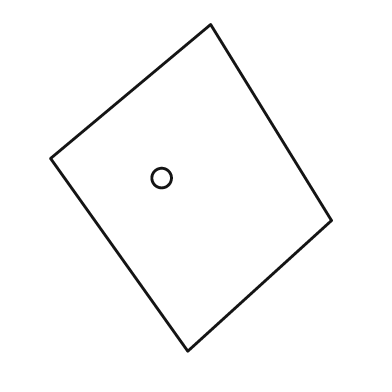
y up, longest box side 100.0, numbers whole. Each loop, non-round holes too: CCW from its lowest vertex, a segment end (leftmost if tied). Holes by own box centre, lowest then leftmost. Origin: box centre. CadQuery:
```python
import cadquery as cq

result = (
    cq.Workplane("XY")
    .moveTo(-1.0, -50.0)
    .lineTo(43.0, -10.0)
    .lineTo(6.0, 50.0)
    .lineTo(-43.0, 9.0)
    .close()
    .moveTo(-9.0, 3.0)
    .circle(3.0)
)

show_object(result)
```